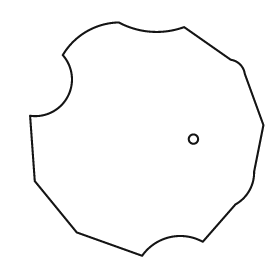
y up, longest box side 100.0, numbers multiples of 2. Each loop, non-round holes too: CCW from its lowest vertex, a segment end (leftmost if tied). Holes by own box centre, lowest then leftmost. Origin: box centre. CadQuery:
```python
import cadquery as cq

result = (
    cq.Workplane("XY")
    .moveTo(-2.0, -50.0)
    .threePointArc((10.0, -42.0), (24.0, -44.0))
    .lineTo(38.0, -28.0)
    .threePointArc((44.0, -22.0), (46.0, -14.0))
    .lineTo(50.0, 6.0)
    .lineTo(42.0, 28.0)
    .threePointArc((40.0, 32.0), (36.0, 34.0))
    .lineTo(16.0, 48.0)
    .threePointArc((2.0, 46.0), (-12.0, 50.0))
    .threePointArc((-26.0, 46.0), (-36.0, 36.0))
    .threePointArc((-34.0, 18.0), (-50.0, 10.0))
    .lineTo(-48.0, -18.0)
    .lineTo(-30.0, -40.0)
    .close()
    .moveTo(20.0, 0.0)
    .circle(2.0)
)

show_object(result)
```